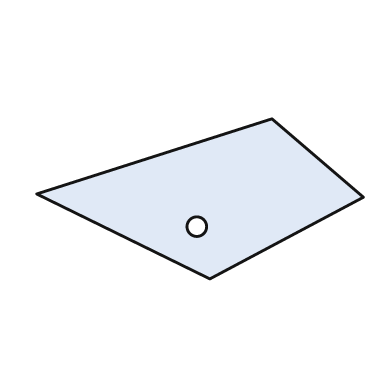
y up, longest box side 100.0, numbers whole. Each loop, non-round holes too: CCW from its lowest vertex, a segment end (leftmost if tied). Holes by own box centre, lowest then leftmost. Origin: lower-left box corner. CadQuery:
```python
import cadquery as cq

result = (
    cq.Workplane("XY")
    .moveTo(53.0, 0.0)
    .lineTo(100.0, 25.0)
    .lineTo(72.0, 49.0)
    .lineTo(0.0, 26.0)
    .close()
    .moveTo(49.0, 16.0)
    .circle(3.0)
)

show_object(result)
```